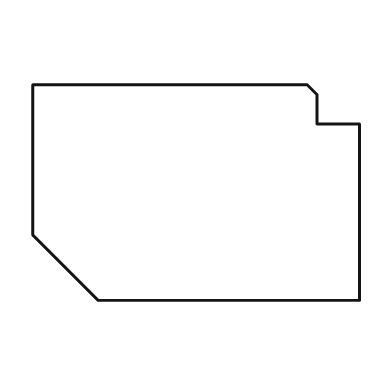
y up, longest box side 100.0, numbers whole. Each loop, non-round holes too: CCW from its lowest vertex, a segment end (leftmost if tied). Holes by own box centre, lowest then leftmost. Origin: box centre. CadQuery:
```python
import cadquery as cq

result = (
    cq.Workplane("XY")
    .moveTo(-30.0, -33.0)
    .lineTo(50.0, -33.0)
    .lineTo(50.0, 21.0)
    .lineTo(37.0, 21.0)
    .lineTo(37.0, 30.0)
    .lineTo(34.0, 33.0)
    .lineTo(-50.0, 33.0)
    .lineTo(-50.0, -13.0)
    .close()
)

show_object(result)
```